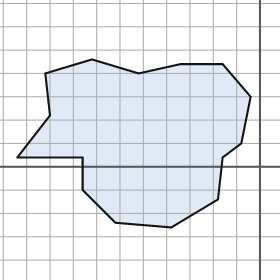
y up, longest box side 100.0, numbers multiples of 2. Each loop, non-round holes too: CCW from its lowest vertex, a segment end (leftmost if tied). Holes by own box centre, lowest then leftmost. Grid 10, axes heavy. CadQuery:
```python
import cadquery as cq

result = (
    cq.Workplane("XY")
    .moveTo(-38.0, -26.0)
    .lineTo(-18.0, -14.0)
    .lineTo(-16.0, 4.0)
    .lineTo(-8.0, 10.0)
    .lineTo(-4.0, 30.0)
    .lineTo(-16.0, 44.0)
    .lineTo(-34.0, 44.0)
    .lineTo(-52.0, 40.0)
    .lineTo(-72.0, 46.0)
    .lineTo(-92.0, 40.0)
    .lineTo(-90.0, 22.0)
    .lineTo(-104.0, 4.0)
    .lineTo(-76.0, 4.0)
    .lineTo(-76.0, -10.0)
    .lineTo(-62.0, -24.0)
    .close()
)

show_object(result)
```